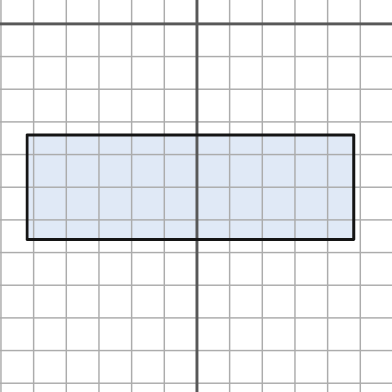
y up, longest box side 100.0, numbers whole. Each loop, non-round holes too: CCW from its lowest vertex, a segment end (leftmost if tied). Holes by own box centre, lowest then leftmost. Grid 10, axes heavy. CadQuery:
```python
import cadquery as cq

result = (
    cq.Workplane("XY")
    .moveTo(-52.0, -66.0)
    .lineTo(48.0, -66.0)
    .lineTo(48.0, -34.0)
    .lineTo(-52.0, -34.0)
    .close()
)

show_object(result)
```